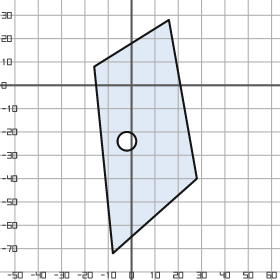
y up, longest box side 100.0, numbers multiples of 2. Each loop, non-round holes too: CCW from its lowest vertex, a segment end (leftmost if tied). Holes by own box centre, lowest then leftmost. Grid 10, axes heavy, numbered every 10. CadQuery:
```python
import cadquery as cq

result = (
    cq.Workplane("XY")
    .moveTo(-8.0, -72.0)
    .lineTo(28.0, -40.0)
    .lineTo(16.0, 28.0)
    .lineTo(-16.0, 8.0)
    .close()
    .moveTo(-2.0, -24.0)
    .circle(4.0)
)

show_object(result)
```